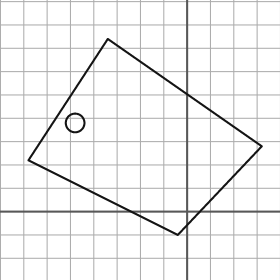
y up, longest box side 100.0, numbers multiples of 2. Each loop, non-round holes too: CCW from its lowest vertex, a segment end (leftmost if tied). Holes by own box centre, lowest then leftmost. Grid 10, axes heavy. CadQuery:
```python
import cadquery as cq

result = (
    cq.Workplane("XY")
    .moveTo(-4.0, -10.0)
    .lineTo(32.0, 28.0)
    .lineTo(-34.0, 74.0)
    .lineTo(-68.0, 22.0)
    .close()
    .moveTo(-48.0, 38.0)
    .circle(4.0)
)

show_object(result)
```